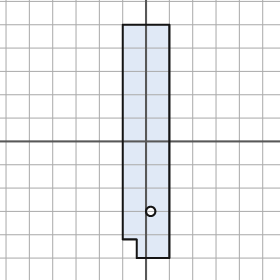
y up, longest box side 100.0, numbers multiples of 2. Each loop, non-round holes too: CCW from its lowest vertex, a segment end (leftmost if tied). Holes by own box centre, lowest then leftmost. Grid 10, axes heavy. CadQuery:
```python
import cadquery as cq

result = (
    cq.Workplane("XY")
    .moveTo(-4.0, -50.0)
    .lineTo(10.0, -50.0)
    .lineTo(10.0, 50.0)
    .lineTo(-10.0, 50.0)
    .lineTo(-10.0, -42.0)
    .lineTo(-4.0, -42.0)
    .close()
    .moveTo(2.0, -30.0)
    .circle(2.0)
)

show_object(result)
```